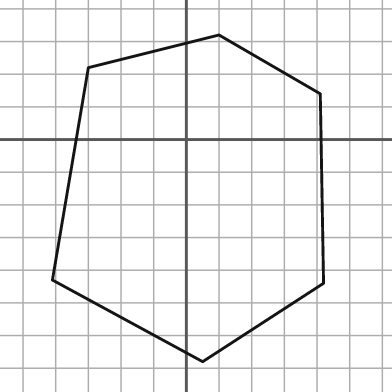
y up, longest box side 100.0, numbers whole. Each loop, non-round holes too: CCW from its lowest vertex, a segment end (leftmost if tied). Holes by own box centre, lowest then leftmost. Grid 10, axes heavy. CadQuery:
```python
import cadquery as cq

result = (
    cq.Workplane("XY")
    .moveTo(5.0, -68.0)
    .lineTo(42.0, -44.0)
    .lineTo(41.0, 14.0)
    .lineTo(10.0, 32.0)
    .lineTo(-30.0, 22.0)
    .lineTo(-41.0, -43.0)
    .close()
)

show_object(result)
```